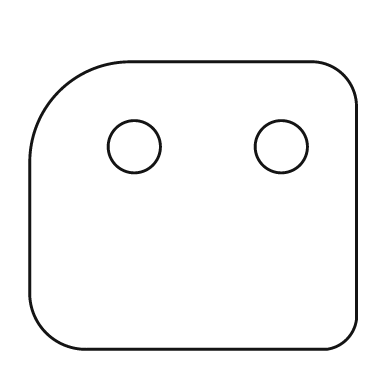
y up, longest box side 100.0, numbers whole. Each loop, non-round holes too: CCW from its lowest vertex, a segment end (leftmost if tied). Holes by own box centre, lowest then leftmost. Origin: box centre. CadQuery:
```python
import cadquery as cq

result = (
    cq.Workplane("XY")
    .moveTo(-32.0, -44.0)
    .lineTo(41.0, -44.0)
    .threePointArc((47.0, -41.0), (50.0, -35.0))
    .lineTo(50.0, 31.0)
    .threePointArc((46.0, 40.0), (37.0, 44.0))
    .lineTo(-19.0, 44.0)
    .threePointArc((-41.0, 35.0), (-50.0, 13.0))
    .lineTo(-50.0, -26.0)
    .threePointArc((-45.0, -39.0), (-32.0, -44.0))
    .close()
    .moveTo(-18.0, 18.0)
    .circle(8.0)
    .moveTo(27.0, 18.0)
    .circle(8.0)
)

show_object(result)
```